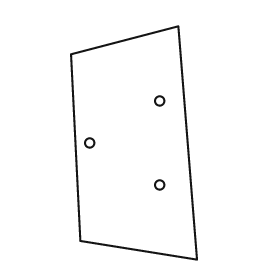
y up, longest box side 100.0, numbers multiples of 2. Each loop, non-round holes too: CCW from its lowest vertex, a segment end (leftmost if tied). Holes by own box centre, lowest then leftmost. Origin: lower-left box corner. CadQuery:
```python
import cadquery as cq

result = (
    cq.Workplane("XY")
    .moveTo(54.0, 0.0)
    .lineTo(46.0, 100.0)
    .lineTo(0.0, 88.0)
    .lineTo(4.0, 8.0)
    .close()
    .moveTo(38.0, 32.0)
    .circle(2.0)
    .moveTo(8.0, 50.0)
    .circle(2.0)
    .moveTo(38.0, 68.0)
    .circle(2.0)
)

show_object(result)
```